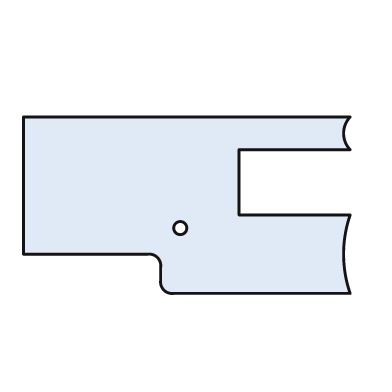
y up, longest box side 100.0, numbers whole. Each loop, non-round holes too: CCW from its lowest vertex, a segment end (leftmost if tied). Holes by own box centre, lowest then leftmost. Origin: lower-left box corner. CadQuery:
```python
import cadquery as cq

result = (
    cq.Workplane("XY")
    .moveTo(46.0, 0.0)
    .lineTo(100.0, 0.0)
    .threePointArc((98.0, 12.0), (100.0, 24.0))
    .lineTo(66.0, 24.0)
    .lineTo(66.0, 44.0)
    .lineTo(100.0, 44.0)
    .threePointArc((98.0, 49.0), (100.0, 54.0))
    .lineTo(0.0, 54.0)
    .lineTo(0.0, 12.0)
    .lineTo(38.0, 12.0)
    .threePointArc((41.0, 11.0), (42.0, 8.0))
    .lineTo(42.0, 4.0)
    .threePointArc((43.0, 1.0), (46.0, 0.0))
    .close()
    .moveTo(48.0, 20.0)
    .circle(2.0)
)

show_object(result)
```